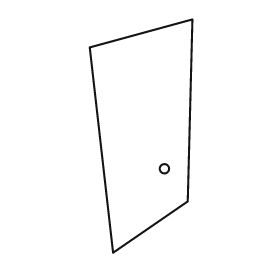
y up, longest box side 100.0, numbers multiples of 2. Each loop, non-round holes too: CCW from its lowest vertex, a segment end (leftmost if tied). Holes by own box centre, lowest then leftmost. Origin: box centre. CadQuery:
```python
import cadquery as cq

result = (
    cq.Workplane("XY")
    .moveTo(-12.0, -50.0)
    .lineTo(20.0, -28.0)
    .lineTo(22.0, 50.0)
    .lineTo(-22.0, 38.0)
    .close()
    .moveTo(10.0, -14.0)
    .circle(2.0)
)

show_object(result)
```